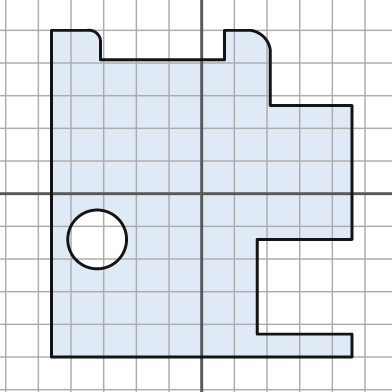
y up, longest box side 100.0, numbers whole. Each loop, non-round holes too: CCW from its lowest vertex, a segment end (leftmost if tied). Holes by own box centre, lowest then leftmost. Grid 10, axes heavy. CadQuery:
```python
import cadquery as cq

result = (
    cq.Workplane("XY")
    .moveTo(-46.0, -50.0)
    .lineTo(46.0, -50.0)
    .lineTo(46.0, -43.0)
    .lineTo(17.0, -43.0)
    .lineTo(17.0, -14.0)
    .lineTo(46.0, -14.0)
    .lineTo(46.0, 27.0)
    .lineTo(21.0, 27.0)
    .lineTo(21.0, 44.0)
    .threePointArc((19.0, 48.0), (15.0, 50.0))
    .lineTo(7.0, 50.0)
    .lineTo(7.0, 41.0)
    .lineTo(-31.0, 41.0)
    .lineTo(-31.0, 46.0)
    .threePointArc((-32.0, 49.0), (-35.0, 50.0))
    .lineTo(-46.0, 50.0)
    .close()
    .moveTo(-32.0, -14.0)
    .circle(9.0)
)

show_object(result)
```